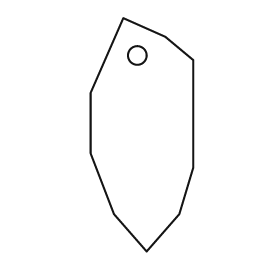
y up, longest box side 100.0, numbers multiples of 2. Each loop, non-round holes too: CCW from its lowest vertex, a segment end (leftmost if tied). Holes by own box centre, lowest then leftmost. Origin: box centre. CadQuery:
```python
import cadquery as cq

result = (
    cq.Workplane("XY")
    .moveTo(2.0, -50.0)
    .lineTo(16.0, -34.0)
    .lineTo(22.0, -14.0)
    .lineTo(22.0, 32.0)
    .lineTo(10.0, 42.0)
    .lineTo(-8.0, 50.0)
    .lineTo(-22.0, 18.0)
    .lineTo(-22.0, -8.0)
    .lineTo(-12.0, -34.0)
    .close()
    .moveTo(-2.0, 34.0)
    .circle(4.0)
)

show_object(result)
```